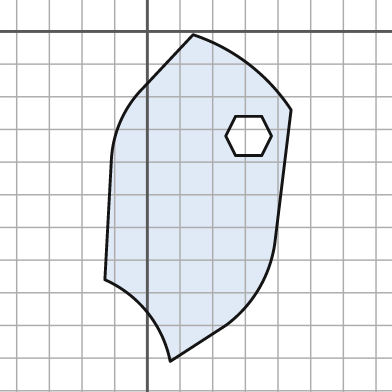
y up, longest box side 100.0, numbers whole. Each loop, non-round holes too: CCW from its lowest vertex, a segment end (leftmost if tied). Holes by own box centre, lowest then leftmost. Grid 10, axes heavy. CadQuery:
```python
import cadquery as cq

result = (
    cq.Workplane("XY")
    .moveTo(7.0, -101.0)
    .lineTo(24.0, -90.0)
    .threePointArc((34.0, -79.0), (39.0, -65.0))
    .lineTo(44.0, -24.0)
    .threePointArc((31.0, -10.0), (14.0, -1.0))
    .lineTo(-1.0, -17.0)
    .threePointArc((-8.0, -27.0), (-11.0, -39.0))
    .lineTo(-13.0, -76.0)
    .threePointArc((0.0, -86.0), (7.0, -101.0))
    .close()
    .moveTo(27.0, -38.0)
    .lineTo(35.0, -38.0)
    .lineTo(38.0, -32.0)
    .lineTo(35.0, -26.0)
    .lineTo(27.0, -26.0)
    .lineTo(24.0, -32.0)
    .close()
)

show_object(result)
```